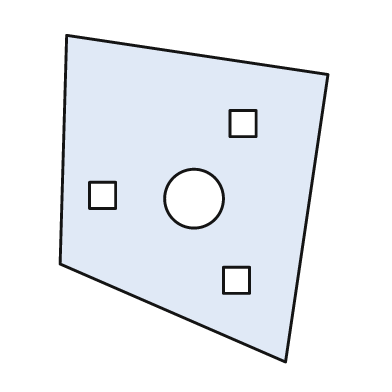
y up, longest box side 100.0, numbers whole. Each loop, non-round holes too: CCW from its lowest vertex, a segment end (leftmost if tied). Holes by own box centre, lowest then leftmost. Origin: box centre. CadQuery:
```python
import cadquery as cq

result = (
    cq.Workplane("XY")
    .moveTo(28.0, -50.0)
    .lineTo(41.0, 38.0)
    .lineTo(-39.0, 50.0)
    .lineTo(-41.0, -20.0)
    .close()
    .moveTo(9.0, -29.0)
    .lineTo(17.0, -29.0)
    .lineTo(17.0, -21.0)
    .lineTo(9.0, -21.0)
    .close()
    .moveTo(0.0, 0.0)
    .circle(9.0)
    .moveTo(-32.0, -3.0)
    .lineTo(-24.0, -3.0)
    .lineTo(-24.0, 5.0)
    .lineTo(-32.0, 5.0)
    .close()
    .moveTo(11.0, 19.0)
    .lineTo(19.0, 19.0)
    .lineTo(19.0, 27.0)
    .lineTo(11.0, 27.0)
    .close()
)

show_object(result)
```